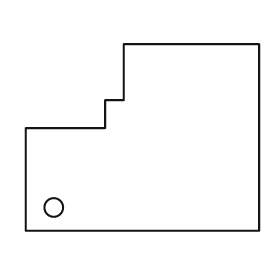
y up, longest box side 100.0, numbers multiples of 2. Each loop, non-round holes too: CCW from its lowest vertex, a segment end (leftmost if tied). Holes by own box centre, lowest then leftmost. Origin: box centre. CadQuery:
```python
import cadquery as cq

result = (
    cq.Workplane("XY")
    .moveTo(-50.0, -40.0)
    .lineTo(50.0, -40.0)
    .lineTo(50.0, 40.0)
    .lineTo(-8.0, 40.0)
    .lineTo(-8.0, 16.0)
    .lineTo(-16.0, 16.0)
    .lineTo(-16.0, 4.0)
    .lineTo(-50.0, 4.0)
    .close()
    .moveTo(-38.0, -30.0)
    .circle(4.0)
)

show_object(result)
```